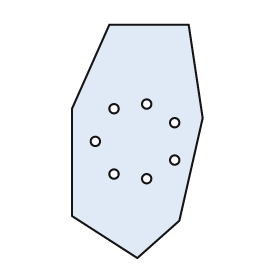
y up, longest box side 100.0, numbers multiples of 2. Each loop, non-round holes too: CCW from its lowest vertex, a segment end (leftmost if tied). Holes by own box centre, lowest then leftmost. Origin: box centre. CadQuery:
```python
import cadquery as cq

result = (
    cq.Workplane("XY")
    .moveTo(0.0, -50.0)
    .lineTo(18.0, -34.0)
    .lineTo(28.0, 10.0)
    .lineTo(22.0, 50.0)
    .lineTo(-12.0, 50.0)
    .lineTo(-28.0, 14.0)
    .lineTo(-28.0, -32.0)
    .close()
    .moveTo(4.0, -16.0)
    .circle(2.0)
    .moveTo(-10.0, -14.0)
    .circle(2.0)
    .moveTo(16.0, -8.0)
    .circle(2.0)
    .moveTo(-18.0, 0.0)
    .circle(2.0)
    .moveTo(16.0, 8.0)
    .circle(2.0)
    .moveTo(-10.0, 14.0)
    .circle(2.0)
    .moveTo(4.0, 16.0)
    .circle(2.0)
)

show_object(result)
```